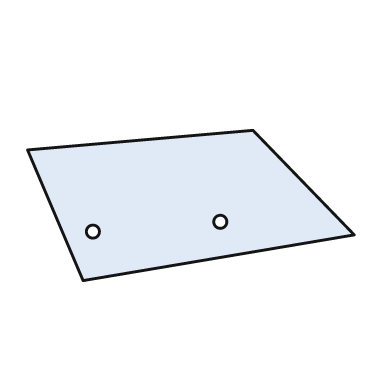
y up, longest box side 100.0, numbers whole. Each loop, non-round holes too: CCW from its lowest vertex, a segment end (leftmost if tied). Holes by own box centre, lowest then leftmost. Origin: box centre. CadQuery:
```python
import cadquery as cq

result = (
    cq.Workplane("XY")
    .moveTo(-33.0, -23.0)
    .lineTo(50.0, -9.0)
    .lineTo(19.0, 23.0)
    .lineTo(-50.0, 17.0)
    .close()
    .moveTo(-30.0, -8.0)
    .circle(2.0)
    .moveTo(9.0, -5.0)
    .circle(2.0)
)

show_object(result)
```